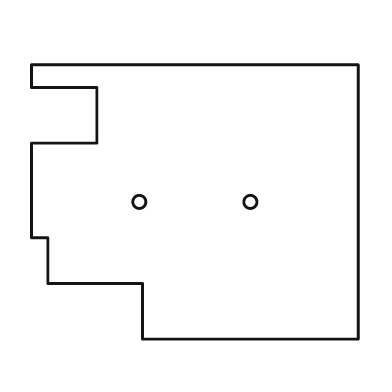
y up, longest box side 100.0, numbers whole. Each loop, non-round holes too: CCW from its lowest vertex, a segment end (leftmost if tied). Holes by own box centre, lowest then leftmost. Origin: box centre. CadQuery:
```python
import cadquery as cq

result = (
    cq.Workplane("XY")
    .moveTo(-16.0, -42.0)
    .lineTo(50.0, -42.0)
    .lineTo(50.0, 42.0)
    .lineTo(-50.0, 42.0)
    .lineTo(-50.0, 35.0)
    .lineTo(-30.0, 35.0)
    .lineTo(-30.0, 18.0)
    .lineTo(-50.0, 18.0)
    .lineTo(-50.0, -11.0)
    .lineTo(-45.0, -11.0)
    .lineTo(-45.0, -25.0)
    .lineTo(-16.0, -25.0)
    .close()
    .moveTo(-17.0, 0.0)
    .circle(2.0)
    .moveTo(17.0, 0.0)
    .circle(2.0)
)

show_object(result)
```